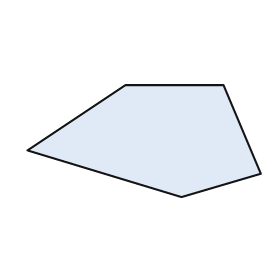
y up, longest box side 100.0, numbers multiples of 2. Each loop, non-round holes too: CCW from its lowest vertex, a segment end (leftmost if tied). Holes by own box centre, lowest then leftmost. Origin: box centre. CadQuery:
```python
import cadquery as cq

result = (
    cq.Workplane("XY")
    .moveTo(16.0, -24.0)
    .lineTo(50.0, -14.0)
    .lineTo(34.0, 24.0)
    .lineTo(-8.0, 24.0)
    .lineTo(-50.0, -4.0)
    .close()
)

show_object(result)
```